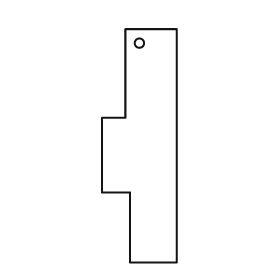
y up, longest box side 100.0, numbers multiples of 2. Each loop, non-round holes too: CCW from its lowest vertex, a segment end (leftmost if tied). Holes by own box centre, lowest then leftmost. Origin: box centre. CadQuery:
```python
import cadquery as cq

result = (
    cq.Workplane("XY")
    .moveTo(-4.0, -50.0)
    .lineTo(16.0, -50.0)
    .lineTo(16.0, 50.0)
    .lineTo(-6.0, 50.0)
    .lineTo(-6.0, 12.0)
    .lineTo(-16.0, 12.0)
    .lineTo(-16.0, -20.0)
    .lineTo(-4.0, -20.0)
    .close()
    .moveTo(0.0, 44.0)
    .circle(2.0)
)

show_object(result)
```